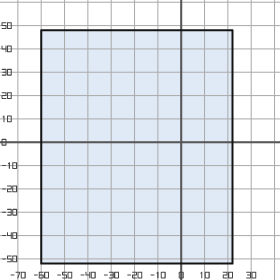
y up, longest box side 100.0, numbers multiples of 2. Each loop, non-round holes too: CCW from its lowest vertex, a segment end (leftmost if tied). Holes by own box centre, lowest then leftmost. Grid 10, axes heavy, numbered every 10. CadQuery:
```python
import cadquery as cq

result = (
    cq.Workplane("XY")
    .moveTo(-60.0, -52.0)
    .lineTo(22.0, -52.0)
    .lineTo(22.0, 48.0)
    .lineTo(-60.0, 48.0)
    .close()
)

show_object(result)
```